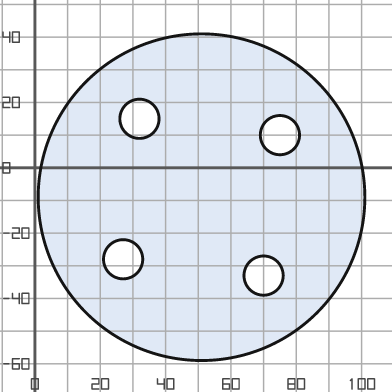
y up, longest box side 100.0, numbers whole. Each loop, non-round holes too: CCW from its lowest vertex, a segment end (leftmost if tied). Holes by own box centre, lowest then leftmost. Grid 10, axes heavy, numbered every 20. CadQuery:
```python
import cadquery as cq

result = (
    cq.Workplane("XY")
    .moveTo(51.0, -9.0)
    .circle(50.0)
    .moveTo(70.0, -33.0)
    .circle(6.0)
    .moveTo(27.0, -28.0)
    .circle(6.0)
    .moveTo(75.0, 10.0)
    .circle(6.0)
    .moveTo(32.0, 15.0)
    .circle(6.0)
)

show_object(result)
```